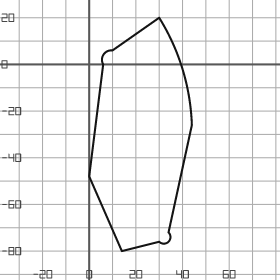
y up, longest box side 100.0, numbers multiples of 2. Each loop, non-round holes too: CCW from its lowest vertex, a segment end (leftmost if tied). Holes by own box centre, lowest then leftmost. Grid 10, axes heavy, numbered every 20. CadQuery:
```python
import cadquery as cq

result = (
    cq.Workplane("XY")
    .moveTo(14.0, -80.0)
    .lineTo(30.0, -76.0)
    .threePointArc((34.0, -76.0), (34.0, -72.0))
    .lineTo(44.0, -26.0)
    .threePointArc((40.0, -2.0), (30.0, 20.0))
    .lineTo(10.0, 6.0)
    .threePointArc((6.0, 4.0), (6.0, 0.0))
    .lineTo(0.0, -48.0)
    .close()
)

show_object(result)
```